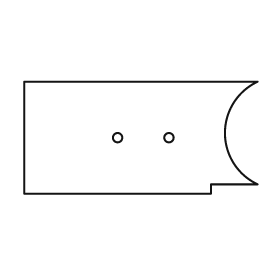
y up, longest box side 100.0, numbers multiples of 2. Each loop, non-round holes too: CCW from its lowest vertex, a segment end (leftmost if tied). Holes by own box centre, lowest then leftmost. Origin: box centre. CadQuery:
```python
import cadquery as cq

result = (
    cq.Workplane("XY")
    .moveTo(-50.0, -24.0)
    .lineTo(30.0, -24.0)
    .lineTo(30.0, -20.0)
    .lineTo(50.0, -20.0)
    .threePointArc((36.0, 2.0), (50.0, 24.0))
    .lineTo(-50.0, 24.0)
    .close()
    .moveTo(-10.0, 0.0)
    .circle(2.0)
    .moveTo(12.0, 0.0)
    .circle(2.0)
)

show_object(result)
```